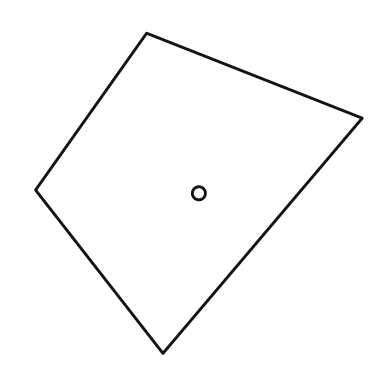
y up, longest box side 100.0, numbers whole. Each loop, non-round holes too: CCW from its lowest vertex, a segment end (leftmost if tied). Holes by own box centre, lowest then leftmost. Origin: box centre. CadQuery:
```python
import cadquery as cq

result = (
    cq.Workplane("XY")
    .moveTo(-11.0, -49.0)
    .lineTo(50.0, 23.0)
    .lineTo(-16.0, 49.0)
    .lineTo(-50.0, 1.0)
    .close()
    .moveTo(0.0, 0.0)
    .circle(2.0)
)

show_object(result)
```